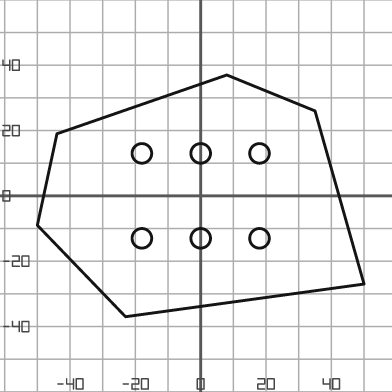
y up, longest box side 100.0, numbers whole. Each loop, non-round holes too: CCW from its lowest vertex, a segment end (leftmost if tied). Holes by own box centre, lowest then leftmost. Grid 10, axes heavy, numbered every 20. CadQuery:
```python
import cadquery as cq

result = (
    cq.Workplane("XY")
    .moveTo(-23.0, -37.0)
    .lineTo(50.0, -27.0)
    .lineTo(35.0, 26.0)
    .lineTo(8.0, 37.0)
    .lineTo(-44.0, 19.0)
    .lineTo(-50.0, -9.0)
    .close()
    .moveTo(-18.0, -13.0)
    .circle(3.0)
    .moveTo(0.0, -13.0)
    .circle(3.0)
    .moveTo(18.0, -13.0)
    .circle(3.0)
    .moveTo(-18.0, 13.0)
    .circle(3.0)
    .moveTo(0.0, 13.0)
    .circle(3.0)
    .moveTo(18.0, 13.0)
    .circle(3.0)
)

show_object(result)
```